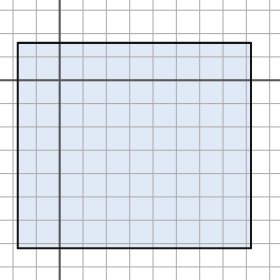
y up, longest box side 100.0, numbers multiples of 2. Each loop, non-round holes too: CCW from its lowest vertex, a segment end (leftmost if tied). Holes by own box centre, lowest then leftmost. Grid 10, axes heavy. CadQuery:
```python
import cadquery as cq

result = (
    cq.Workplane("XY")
    .moveTo(-18.0, -72.0)
    .lineTo(82.0, -72.0)
    .lineTo(82.0, 16.0)
    .lineTo(-18.0, 16.0)
    .close()
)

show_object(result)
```